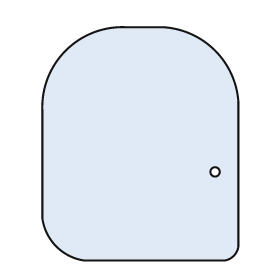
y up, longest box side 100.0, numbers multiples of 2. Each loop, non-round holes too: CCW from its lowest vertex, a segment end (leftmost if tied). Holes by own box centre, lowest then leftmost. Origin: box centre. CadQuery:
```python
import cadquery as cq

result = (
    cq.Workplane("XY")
    .moveTo(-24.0, -50.0)
    .lineTo(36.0, -50.0)
    .threePointArc((40.0, -48.0), (42.0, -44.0))
    .lineTo(42.0, 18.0)
    .threePointArc((32.0, 40.0), (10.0, 50.0))
    .lineTo(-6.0, 50.0)
    .threePointArc((-32.0, 40.0), (-42.0, 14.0))
    .lineTo(-42.0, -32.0)
    .threePointArc((-36.0, -44.0), (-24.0, -50.0))
    .close()
    .moveTo(32.0, -12.0)
    .circle(2.0)
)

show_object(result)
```